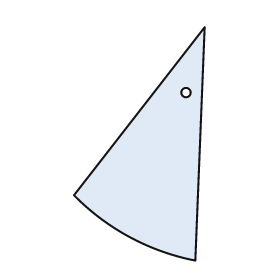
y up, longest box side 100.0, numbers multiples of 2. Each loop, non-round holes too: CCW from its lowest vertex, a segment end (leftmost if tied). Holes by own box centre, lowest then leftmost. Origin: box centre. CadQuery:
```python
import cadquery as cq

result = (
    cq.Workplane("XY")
    .moveTo(24.0, -50.0)
    .lineTo(28.0, 50.0)
    .lineTo(-28.0, -22.0)
    .threePointArc((-4.0, -40.0), (24.0, -50.0))
    .close()
    .moveTo(20.0, 22.0)
    .circle(2.0)
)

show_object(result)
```